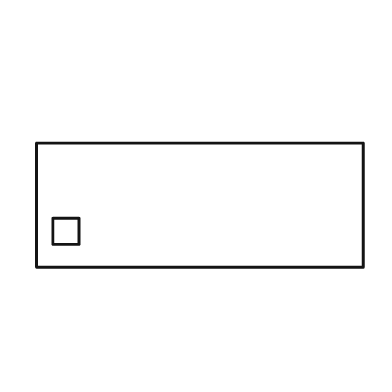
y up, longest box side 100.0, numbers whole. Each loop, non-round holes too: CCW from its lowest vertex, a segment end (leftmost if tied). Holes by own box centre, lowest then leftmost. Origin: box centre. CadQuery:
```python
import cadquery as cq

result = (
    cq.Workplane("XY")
    .moveTo(-50.0, -19.0)
    .lineTo(50.0, -19.0)
    .lineTo(50.0, 19.0)
    .lineTo(-50.0, 19.0)
    .close()
    .moveTo(-45.0, -12.0)
    .lineTo(-37.0, -12.0)
    .lineTo(-37.0, -4.0)
    .lineTo(-45.0, -4.0)
    .close()
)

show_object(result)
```